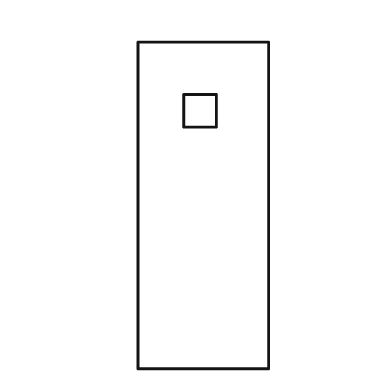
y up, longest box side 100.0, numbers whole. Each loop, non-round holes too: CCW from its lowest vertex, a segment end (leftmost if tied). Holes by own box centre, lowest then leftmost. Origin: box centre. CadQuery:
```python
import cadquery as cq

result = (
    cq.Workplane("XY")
    .moveTo(-20.0, -50.0)
    .lineTo(20.0, -50.0)
    .lineTo(20.0, 50.0)
    .lineTo(-20.0, 50.0)
    .close()
    .moveTo(-6.0, 24.0)
    .lineTo(4.0, 24.0)
    .lineTo(4.0, 34.0)
    .lineTo(-6.0, 34.0)
    .close()
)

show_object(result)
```